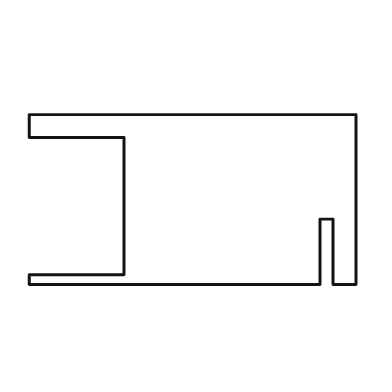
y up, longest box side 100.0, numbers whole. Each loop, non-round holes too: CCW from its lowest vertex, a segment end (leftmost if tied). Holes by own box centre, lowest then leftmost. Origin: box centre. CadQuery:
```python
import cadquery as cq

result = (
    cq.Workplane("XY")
    .moveTo(-50.0, -26.0)
    .lineTo(39.0, -26.0)
    .lineTo(39.0, -6.0)
    .lineTo(43.0, -6.0)
    .lineTo(43.0, -26.0)
    .lineTo(50.0, -26.0)
    .lineTo(50.0, 26.0)
    .lineTo(-50.0, 26.0)
    .lineTo(-50.0, 19.0)
    .lineTo(-21.0, 19.0)
    .lineTo(-21.0, -23.0)
    .lineTo(-50.0, -23.0)
    .close()
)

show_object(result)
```